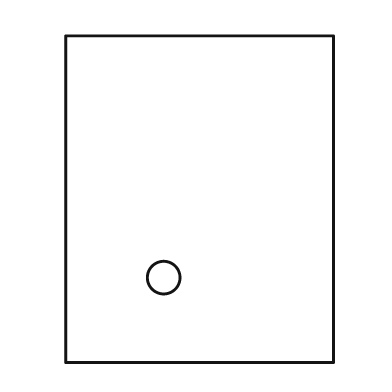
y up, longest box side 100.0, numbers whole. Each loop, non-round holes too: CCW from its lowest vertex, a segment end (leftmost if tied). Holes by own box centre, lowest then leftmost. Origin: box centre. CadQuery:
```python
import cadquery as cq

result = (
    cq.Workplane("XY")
    .moveTo(-41.0, -50.0)
    .lineTo(41.0, -50.0)
    .lineTo(41.0, 50.0)
    .lineTo(-41.0, 50.0)
    .close()
    .moveTo(-11.0, -24.0)
    .circle(5.0)
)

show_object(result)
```